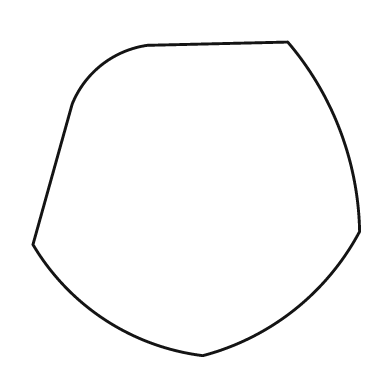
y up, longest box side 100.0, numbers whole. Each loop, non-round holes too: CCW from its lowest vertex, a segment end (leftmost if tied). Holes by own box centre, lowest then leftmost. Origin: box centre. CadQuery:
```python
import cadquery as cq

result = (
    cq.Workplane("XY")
    .moveTo(2.0, -48.0)
    .threePointArc((30.0, -34.0), (50.0, -10.0))
    .threePointArc((44.0, 21.0), (28.0, 48.0))
    .lineTo(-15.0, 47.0)
    .threePointArc((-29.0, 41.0), (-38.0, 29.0))
    .lineTo(-50.0, -14.0)
    .threePointArc((-28.0, -37.0), (2.0, -48.0))
    .close()
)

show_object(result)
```